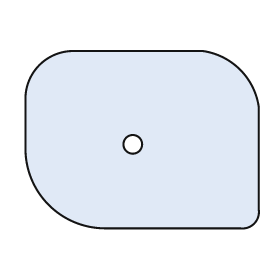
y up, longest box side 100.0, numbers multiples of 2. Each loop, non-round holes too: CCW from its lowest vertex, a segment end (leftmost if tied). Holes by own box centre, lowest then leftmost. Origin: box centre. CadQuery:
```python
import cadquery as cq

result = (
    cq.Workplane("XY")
    .moveTo(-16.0, -38.0)
    .lineTo(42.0, -38.0)
    .threePointArc((48.0, -36.0), (50.0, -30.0))
    .lineTo(50.0, 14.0)
    .threePointArc((42.0, 30.0), (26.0, 38.0))
    .lineTo(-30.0, 38.0)
    .threePointArc((-44.0, 32.0), (-50.0, 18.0))
    .lineTo(-50.0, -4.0)
    .threePointArc((-40.0, -28.0), (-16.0, -38.0))
    .close()
    .moveTo(-4.0, -2.0)
    .circle(4.0)
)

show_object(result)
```